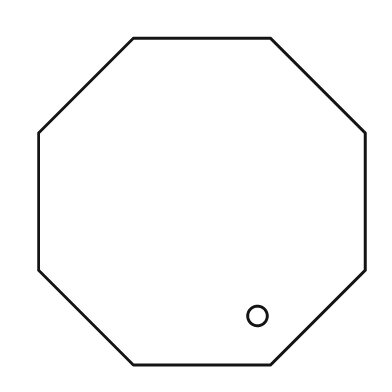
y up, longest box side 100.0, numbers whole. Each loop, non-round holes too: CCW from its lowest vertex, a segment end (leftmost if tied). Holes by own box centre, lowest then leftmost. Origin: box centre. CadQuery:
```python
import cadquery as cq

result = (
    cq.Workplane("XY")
    .moveTo(-21.0, -50.0)
    .lineTo(21.0, -50.0)
    .lineTo(50.0, -21.0)
    .lineTo(50.0, 21.0)
    .lineTo(21.0, 50.0)
    .lineTo(-21.0, 50.0)
    .lineTo(-50.0, 21.0)
    .lineTo(-50.0, -21.0)
    .close()
    .moveTo(17.0, -35.0)
    .circle(3.0)
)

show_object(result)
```